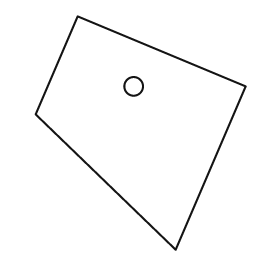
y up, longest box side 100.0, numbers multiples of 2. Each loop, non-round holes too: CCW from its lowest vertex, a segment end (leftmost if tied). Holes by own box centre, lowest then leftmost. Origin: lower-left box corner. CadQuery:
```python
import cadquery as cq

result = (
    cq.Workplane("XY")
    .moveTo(60.0, 0.0)
    .lineTo(90.0, 70.0)
    .lineTo(18.0, 100.0)
    .lineTo(0.0, 58.0)
    .close()
    .moveTo(42.0, 70.0)
    .circle(4.0)
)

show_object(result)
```